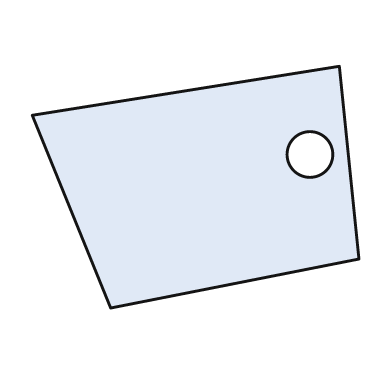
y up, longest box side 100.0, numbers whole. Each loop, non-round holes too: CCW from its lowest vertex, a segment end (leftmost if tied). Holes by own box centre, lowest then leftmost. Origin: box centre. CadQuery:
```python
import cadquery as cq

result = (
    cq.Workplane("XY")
    .moveTo(-26.0, -37.0)
    .lineTo(50.0, -22.0)
    .lineTo(44.0, 37.0)
    .lineTo(-50.0, 22.0)
    .close()
    .moveTo(35.0, 10.0)
    .circle(7.0)
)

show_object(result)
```